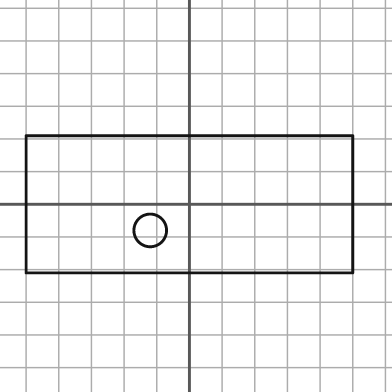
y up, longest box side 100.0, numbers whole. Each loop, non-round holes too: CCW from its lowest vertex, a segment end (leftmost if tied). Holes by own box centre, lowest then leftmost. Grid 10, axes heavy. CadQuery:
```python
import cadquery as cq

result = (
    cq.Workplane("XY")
    .moveTo(-50.0, -21.0)
    .lineTo(50.0, -21.0)
    .lineTo(50.0, 21.0)
    .lineTo(-50.0, 21.0)
    .close()
    .moveTo(-12.0, -8.0)
    .circle(5.0)
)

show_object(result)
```